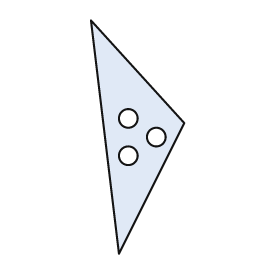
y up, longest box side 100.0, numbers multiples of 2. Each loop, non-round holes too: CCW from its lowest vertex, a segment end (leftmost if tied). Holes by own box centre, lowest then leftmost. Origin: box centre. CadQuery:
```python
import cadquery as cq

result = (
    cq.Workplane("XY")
    .moveTo(-8.0, -50.0)
    .lineTo(20.0, 6.0)
    .lineTo(-20.0, 50.0)
    .close()
    .moveTo(-4.0, -8.0)
    .circle(4.0)
    .moveTo(8.0, 0.0)
    .circle(4.0)
    .moveTo(-4.0, 8.0)
    .circle(4.0)
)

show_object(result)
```